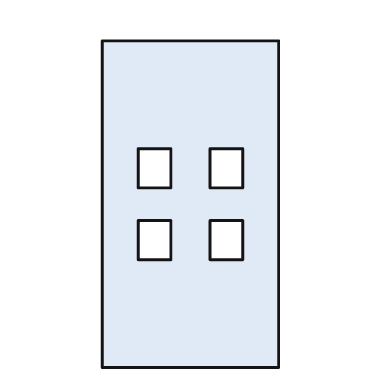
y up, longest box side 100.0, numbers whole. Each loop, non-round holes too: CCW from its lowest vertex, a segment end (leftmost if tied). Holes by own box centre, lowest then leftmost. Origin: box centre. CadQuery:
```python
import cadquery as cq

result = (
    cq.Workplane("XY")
    .moveTo(-27.0, -50.0)
    .lineTo(27.0, -50.0)
    .lineTo(27.0, 50.0)
    .lineTo(-27.0, 50.0)
    .close()
    .moveTo(-16.0, -17.0)
    .lineTo(-6.0, -17.0)
    .lineTo(-6.0, -5.0)
    .lineTo(-16.0, -5.0)
    .close()
    .moveTo(6.0, -17.0)
    .lineTo(16.0, -17.0)
    .lineTo(16.0, -5.0)
    .lineTo(6.0, -5.0)
    .close()
    .moveTo(-16.0, 5.0)
    .lineTo(-6.0, 5.0)
    .lineTo(-6.0, 17.0)
    .lineTo(-16.0, 17.0)
    .close()
    .moveTo(6.0, 5.0)
    .lineTo(16.0, 5.0)
    .lineTo(16.0, 17.0)
    .lineTo(6.0, 17.0)
    .close()
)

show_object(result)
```